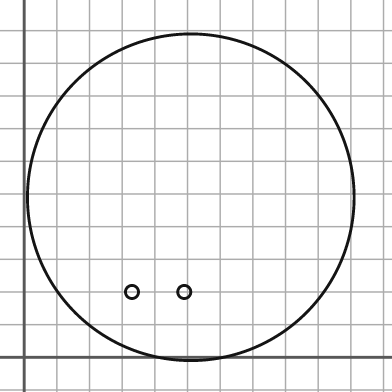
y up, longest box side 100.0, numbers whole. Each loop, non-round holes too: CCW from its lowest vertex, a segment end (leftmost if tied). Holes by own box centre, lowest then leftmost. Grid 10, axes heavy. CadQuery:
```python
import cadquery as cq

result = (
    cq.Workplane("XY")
    .moveTo(51.0, 49.0)
    .circle(50.0)
    .moveTo(33.0, 20.0)
    .circle(2.0)
    .moveTo(49.0, 20.0)
    .circle(2.0)
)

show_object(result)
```